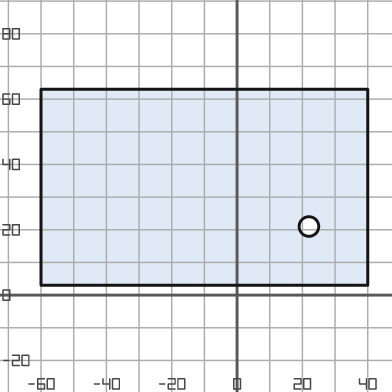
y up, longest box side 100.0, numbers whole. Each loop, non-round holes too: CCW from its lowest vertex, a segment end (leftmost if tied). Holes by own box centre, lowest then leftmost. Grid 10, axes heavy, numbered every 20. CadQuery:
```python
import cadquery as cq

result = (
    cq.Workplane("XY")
    .moveTo(-60.0, 3.0)
    .lineTo(40.0, 3.0)
    .lineTo(40.0, 63.0)
    .lineTo(-60.0, 63.0)
    .close()
    .moveTo(22.0, 21.0)
    .circle(3.0)
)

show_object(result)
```